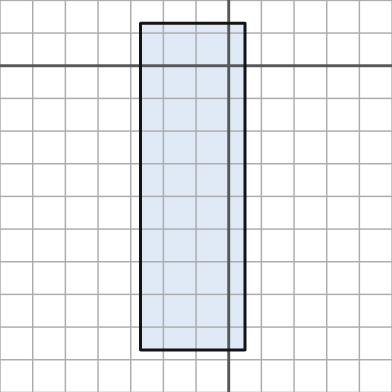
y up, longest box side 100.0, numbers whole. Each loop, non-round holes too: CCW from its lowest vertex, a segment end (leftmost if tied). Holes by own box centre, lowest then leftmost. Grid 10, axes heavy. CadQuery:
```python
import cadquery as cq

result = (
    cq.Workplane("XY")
    .moveTo(-27.0, -87.0)
    .lineTo(5.0, -87.0)
    .lineTo(5.0, 13.0)
    .lineTo(-27.0, 13.0)
    .close()
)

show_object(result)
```